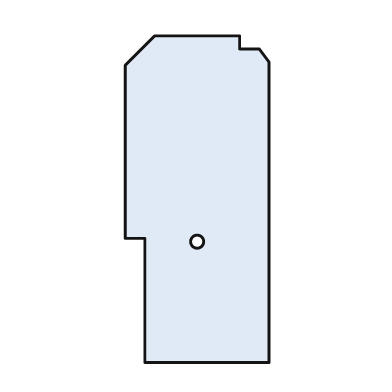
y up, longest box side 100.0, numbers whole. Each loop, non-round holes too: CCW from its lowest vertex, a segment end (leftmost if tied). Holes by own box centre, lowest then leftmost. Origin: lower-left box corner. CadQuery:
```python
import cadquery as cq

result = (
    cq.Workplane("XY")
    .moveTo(6.0, 0.0)
    .lineTo(44.0, 0.0)
    .lineTo(44.0, 92.0)
    .lineTo(41.0, 96.0)
    .lineTo(35.0, 96.0)
    .lineTo(35.0, 100.0)
    .lineTo(9.0, 100.0)
    .lineTo(0.0, 91.0)
    .lineTo(0.0, 38.0)
    .lineTo(6.0, 38.0)
    .close()
    .moveTo(22.0, 37.0)
    .circle(2.0)
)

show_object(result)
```